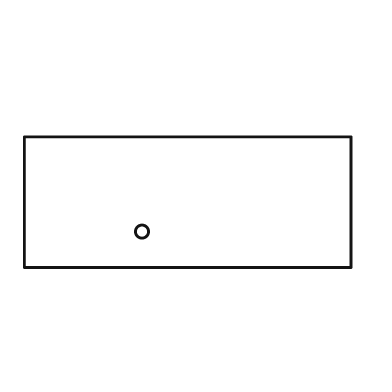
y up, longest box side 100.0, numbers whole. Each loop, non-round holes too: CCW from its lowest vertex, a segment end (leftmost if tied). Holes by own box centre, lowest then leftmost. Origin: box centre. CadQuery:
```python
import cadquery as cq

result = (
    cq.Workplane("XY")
    .moveTo(-50.0, -20.0)
    .lineTo(50.0, -20.0)
    .lineTo(50.0, 20.0)
    .lineTo(-50.0, 20.0)
    .close()
    .moveTo(-14.0, -9.0)
    .circle(2.0)
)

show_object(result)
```